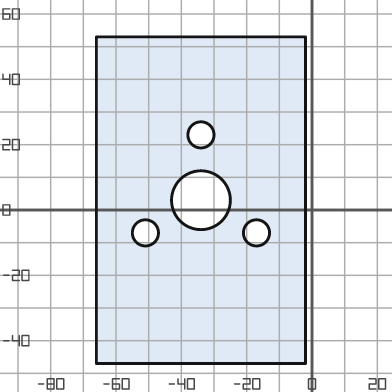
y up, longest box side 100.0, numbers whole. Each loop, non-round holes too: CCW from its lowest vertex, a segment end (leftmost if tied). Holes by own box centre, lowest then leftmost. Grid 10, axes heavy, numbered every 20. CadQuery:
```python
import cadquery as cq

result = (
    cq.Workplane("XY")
    .moveTo(-66.0, -47.0)
    .lineTo(-2.0, -47.0)
    .lineTo(-2.0, 53.0)
    .lineTo(-66.0, 53.0)
    .close()
    .moveTo(-51.0, -7.0)
    .circle(4.0)
    .moveTo(-17.0, -7.0)
    .circle(4.0)
    .moveTo(-34.0, 3.0)
    .circle(9.0)
    .moveTo(-34.0, 23.0)
    .circle(4.0)
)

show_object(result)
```